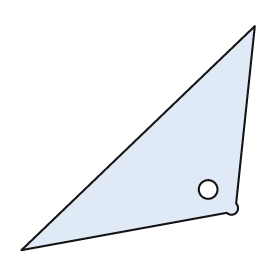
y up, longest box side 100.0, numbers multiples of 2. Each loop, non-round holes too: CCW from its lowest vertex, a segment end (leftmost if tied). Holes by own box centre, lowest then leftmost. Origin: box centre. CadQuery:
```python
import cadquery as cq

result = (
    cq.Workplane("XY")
    .moveTo(-50.0, -48.0)
    .lineTo(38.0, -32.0)
    .threePointArc((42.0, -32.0), (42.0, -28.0))
    .lineTo(50.0, 48.0)
    .close()
    .moveTo(30.0, -22.0)
    .circle(4.0)
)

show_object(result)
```